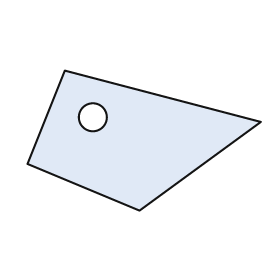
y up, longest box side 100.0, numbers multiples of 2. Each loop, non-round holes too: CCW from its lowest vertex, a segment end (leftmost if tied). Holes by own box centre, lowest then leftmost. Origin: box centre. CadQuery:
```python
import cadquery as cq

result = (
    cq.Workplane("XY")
    .moveTo(-2.0, -30.0)
    .lineTo(50.0, 8.0)
    .lineTo(-34.0, 30.0)
    .lineTo(-50.0, -10.0)
    .close()
    .moveTo(-22.0, 10.0)
    .circle(6.0)
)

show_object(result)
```